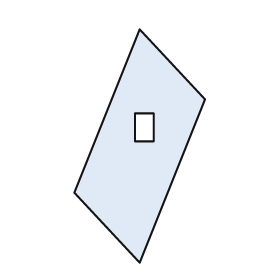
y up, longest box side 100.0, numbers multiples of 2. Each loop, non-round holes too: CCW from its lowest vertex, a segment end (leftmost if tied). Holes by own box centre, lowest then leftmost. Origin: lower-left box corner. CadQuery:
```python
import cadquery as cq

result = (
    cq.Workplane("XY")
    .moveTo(28.0, 0.0)
    .lineTo(56.0, 70.0)
    .lineTo(28.0, 100.0)
    .lineTo(0.0, 30.0)
    .close()
    .moveTo(26.0, 52.0)
    .lineTo(34.0, 52.0)
    .lineTo(34.0, 64.0)
    .lineTo(26.0, 64.0)
    .close()
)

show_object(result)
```